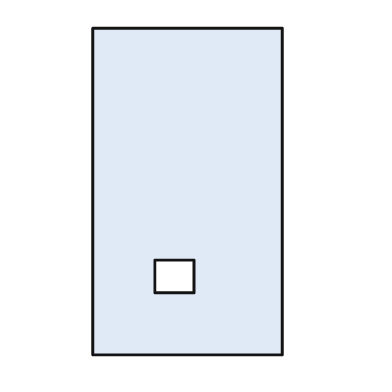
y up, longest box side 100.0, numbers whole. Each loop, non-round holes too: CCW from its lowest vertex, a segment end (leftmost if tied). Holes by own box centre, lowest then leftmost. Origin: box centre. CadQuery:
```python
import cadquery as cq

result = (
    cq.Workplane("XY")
    .moveTo(-29.0, -50.0)
    .lineTo(29.0, -50.0)
    .lineTo(29.0, 50.0)
    .lineTo(-29.0, 50.0)
    .close()
    .moveTo(-10.0, -31.0)
    .lineTo(2.0, -31.0)
    .lineTo(2.0, -21.0)
    .lineTo(-10.0, -21.0)
    .close()
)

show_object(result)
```